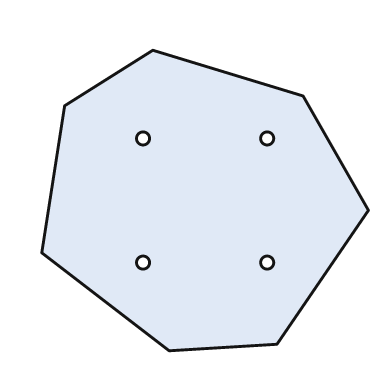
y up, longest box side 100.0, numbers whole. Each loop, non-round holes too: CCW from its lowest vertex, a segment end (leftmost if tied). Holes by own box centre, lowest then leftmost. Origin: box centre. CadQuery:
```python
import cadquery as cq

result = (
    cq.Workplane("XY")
    .moveTo(-11.0, -46.0)
    .lineTo(22.0, -44.0)
    .lineTo(50.0, -3.0)
    .lineTo(30.0, 32.0)
    .lineTo(-16.0, 46.0)
    .lineTo(-43.0, 29.0)
    .lineTo(-50.0, -16.0)
    .close()
    .moveTo(-19.0, -19.0)
    .circle(2.0)
    .moveTo(19.0, -19.0)
    .circle(2.0)
    .moveTo(-19.0, 19.0)
    .circle(2.0)
    .moveTo(19.0, 19.0)
    .circle(2.0)
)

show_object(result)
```